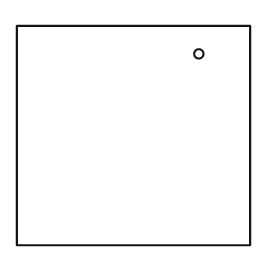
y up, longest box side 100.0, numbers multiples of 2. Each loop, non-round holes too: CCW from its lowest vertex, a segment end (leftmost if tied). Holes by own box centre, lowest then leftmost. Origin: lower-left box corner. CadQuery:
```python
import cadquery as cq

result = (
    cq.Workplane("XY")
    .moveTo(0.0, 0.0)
    .lineTo(100.0, 0.0)
    .lineTo(100.0, 94.0)
    .lineTo(0.0, 94.0)
    .close()
    .moveTo(78.0, 82.0)
    .circle(2.0)
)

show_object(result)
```